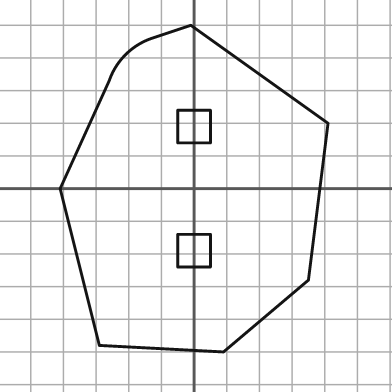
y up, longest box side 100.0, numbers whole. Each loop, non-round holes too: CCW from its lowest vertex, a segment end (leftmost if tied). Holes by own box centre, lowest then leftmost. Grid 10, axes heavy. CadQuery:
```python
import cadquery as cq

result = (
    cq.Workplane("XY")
    .moveTo(9.0, -50.0)
    .lineTo(35.0, -28.0)
    .lineTo(41.0, 20.0)
    .lineTo(-1.0, 50.0)
    .lineTo(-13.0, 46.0)
    .threePointArc((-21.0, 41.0), (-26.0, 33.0))
    .lineTo(-41.0, 0.0)
    .lineTo(-29.0, -48.0)
    .close()
    .moveTo(-5.0, -24.0)
    .lineTo(5.0, -24.0)
    .lineTo(5.0, -14.0)
    .lineTo(-5.0, -14.0)
    .close()
    .moveTo(-5.0, 14.0)
    .lineTo(5.0, 14.0)
    .lineTo(5.0, 24.0)
    .lineTo(-5.0, 24.0)
    .close()
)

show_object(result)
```